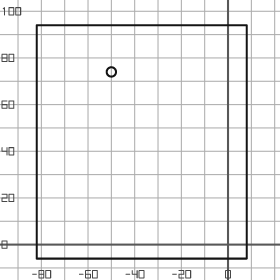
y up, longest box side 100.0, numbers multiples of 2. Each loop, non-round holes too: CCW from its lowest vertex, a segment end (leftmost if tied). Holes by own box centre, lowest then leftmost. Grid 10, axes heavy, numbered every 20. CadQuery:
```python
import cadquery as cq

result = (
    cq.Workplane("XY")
    .moveTo(-82.0, -6.0)
    .lineTo(8.0, -6.0)
    .lineTo(8.0, 94.0)
    .lineTo(-82.0, 94.0)
    .close()
    .moveTo(-50.0, 74.0)
    .circle(2.0)
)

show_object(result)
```